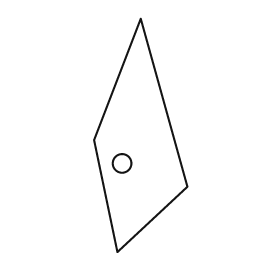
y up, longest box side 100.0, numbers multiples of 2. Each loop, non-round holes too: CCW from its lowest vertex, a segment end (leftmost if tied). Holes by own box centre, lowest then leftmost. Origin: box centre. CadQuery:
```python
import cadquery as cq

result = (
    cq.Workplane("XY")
    .moveTo(-10.0, -50.0)
    .lineTo(20.0, -22.0)
    .lineTo(0.0, 50.0)
    .lineTo(-20.0, -2.0)
    .close()
    .moveTo(-8.0, -12.0)
    .circle(4.0)
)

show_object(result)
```